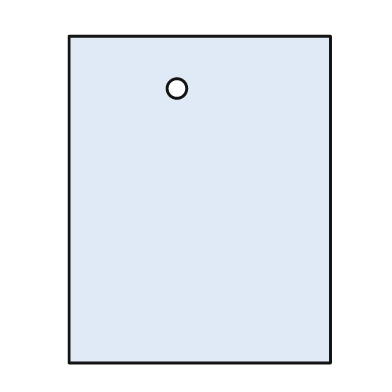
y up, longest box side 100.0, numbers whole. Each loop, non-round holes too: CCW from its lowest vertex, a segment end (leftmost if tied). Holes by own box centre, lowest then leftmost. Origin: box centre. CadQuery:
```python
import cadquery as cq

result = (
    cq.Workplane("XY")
    .moveTo(-40.0, -50.0)
    .lineTo(40.0, -50.0)
    .lineTo(40.0, 50.0)
    .lineTo(-40.0, 50.0)
    .close()
    .moveTo(-7.0, 34.0)
    .circle(3.0)
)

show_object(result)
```